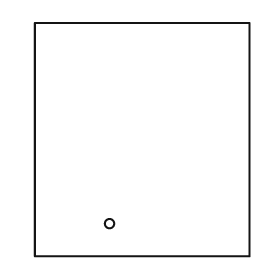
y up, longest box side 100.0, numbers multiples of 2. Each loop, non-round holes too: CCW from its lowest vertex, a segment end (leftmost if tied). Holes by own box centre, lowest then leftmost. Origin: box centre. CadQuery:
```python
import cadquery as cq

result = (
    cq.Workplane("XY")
    .moveTo(-46.0, -50.0)
    .lineTo(46.0, -50.0)
    .lineTo(46.0, 50.0)
    .lineTo(-46.0, 50.0)
    .close()
    .moveTo(-14.0, -36.0)
    .circle(2.0)
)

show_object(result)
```